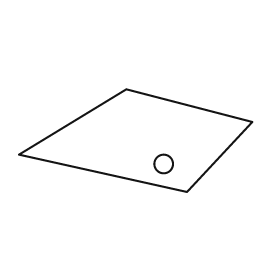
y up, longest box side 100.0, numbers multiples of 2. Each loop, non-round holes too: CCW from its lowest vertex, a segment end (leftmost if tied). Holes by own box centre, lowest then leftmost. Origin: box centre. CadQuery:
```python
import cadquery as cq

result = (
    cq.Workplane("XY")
    .moveTo(22.0, -22.0)
    .lineTo(50.0, 8.0)
    .lineTo(-4.0, 22.0)
    .lineTo(-50.0, -6.0)
    .close()
    .moveTo(12.0, -10.0)
    .circle(4.0)
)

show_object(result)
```